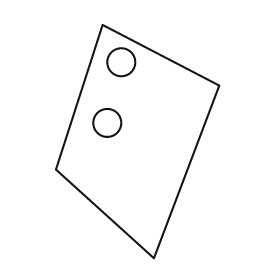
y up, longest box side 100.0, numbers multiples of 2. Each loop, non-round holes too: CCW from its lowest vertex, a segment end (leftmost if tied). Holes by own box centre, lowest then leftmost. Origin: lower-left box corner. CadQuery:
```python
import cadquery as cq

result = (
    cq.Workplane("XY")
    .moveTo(42.0, 0.0)
    .lineTo(70.0, 74.0)
    .lineTo(20.0, 100.0)
    .lineTo(0.0, 38.0)
    .close()
    .moveTo(22.0, 58.0)
    .circle(6.0)
    .moveTo(28.0, 84.0)
    .circle(6.0)
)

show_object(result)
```